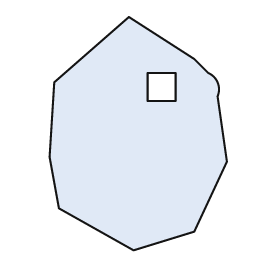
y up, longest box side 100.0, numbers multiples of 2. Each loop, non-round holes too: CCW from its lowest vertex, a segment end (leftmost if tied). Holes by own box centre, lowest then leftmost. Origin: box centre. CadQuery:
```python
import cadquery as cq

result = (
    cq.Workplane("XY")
    .moveTo(-2.0, -50.0)
    .lineTo(24.0, -42.0)
    .lineTo(38.0, -12.0)
    .lineTo(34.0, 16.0)
    .threePointArc((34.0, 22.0), (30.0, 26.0))
    .lineTo(24.0, 32.0)
    .lineTo(-4.0, 50.0)
    .lineTo(-36.0, 22.0)
    .lineTo(-38.0, -10.0)
    .lineTo(-34.0, -32.0)
    .close()
    .moveTo(4.0, 14.0)
    .lineTo(16.0, 14.0)
    .lineTo(16.0, 26.0)
    .lineTo(4.0, 26.0)
    .close()
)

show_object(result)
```